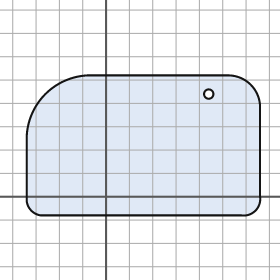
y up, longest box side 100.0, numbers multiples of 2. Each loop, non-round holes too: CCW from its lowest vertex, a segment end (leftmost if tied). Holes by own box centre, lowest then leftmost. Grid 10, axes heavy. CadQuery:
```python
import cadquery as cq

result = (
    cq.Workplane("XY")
    .moveTo(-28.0, -8.0)
    .lineTo(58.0, -8.0)
    .threePointArc((64.0, -6.0), (66.0, 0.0))
    .lineTo(66.0, 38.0)
    .threePointArc((62.0, 48.0), (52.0, 52.0))
    .lineTo(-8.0, 52.0)
    .threePointArc((-26.0, 44.0), (-34.0, 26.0))
    .lineTo(-34.0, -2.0)
    .threePointArc((-32.0, -6.0), (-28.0, -8.0))
    .close()
    .moveTo(44.0, 44.0)
    .circle(2.0)
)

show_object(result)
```